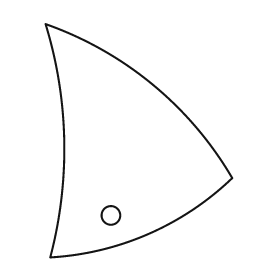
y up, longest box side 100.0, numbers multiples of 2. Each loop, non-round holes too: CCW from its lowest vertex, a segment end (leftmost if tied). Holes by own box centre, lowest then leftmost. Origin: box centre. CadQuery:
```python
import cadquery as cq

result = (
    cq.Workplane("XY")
    .moveTo(-38.0, -50.0)
    .threePointArc((4.0, -40.0), (40.0, -16.0))
    .threePointArc((6.0, 24.0), (-40.0, 50.0))
    .threePointArc((-32.0, 0.0), (-38.0, -50.0))
    .close()
    .moveTo(-12.0, -32.0)
    .circle(4.0)
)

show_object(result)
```